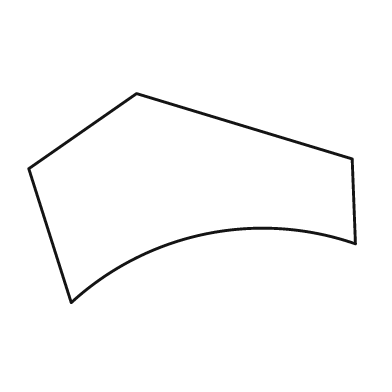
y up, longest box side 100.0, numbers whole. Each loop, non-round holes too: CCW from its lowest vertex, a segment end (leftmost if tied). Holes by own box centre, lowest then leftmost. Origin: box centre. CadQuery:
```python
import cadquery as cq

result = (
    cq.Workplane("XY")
    .moveTo(-37.0, -32.0)
    .threePointArc((4.0, -11.0), (50.0, -14.0))
    .lineTo(49.0, 12.0)
    .lineTo(-17.0, 32.0)
    .lineTo(-50.0, 9.0)
    .close()
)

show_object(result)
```